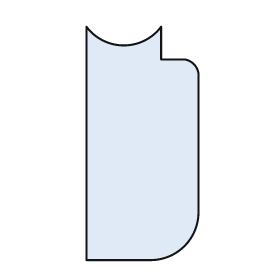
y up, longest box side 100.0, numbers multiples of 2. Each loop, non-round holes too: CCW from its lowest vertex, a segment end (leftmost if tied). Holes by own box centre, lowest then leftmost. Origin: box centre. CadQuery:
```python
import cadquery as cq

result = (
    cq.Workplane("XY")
    .moveTo(-24.0, -50.0)
    .lineTo(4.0, -50.0)
    .threePointArc((18.0, -44.0), (24.0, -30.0))
    .lineTo(24.0, 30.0)
    .threePointArc((22.0, 34.0), (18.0, 36.0))
    .lineTo(8.0, 36.0)
    .lineTo(8.0, 50.0)
    .threePointArc((-8.0, 42.0), (-24.0, 50.0))
    .close()
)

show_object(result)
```